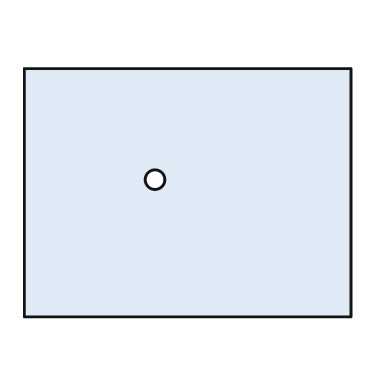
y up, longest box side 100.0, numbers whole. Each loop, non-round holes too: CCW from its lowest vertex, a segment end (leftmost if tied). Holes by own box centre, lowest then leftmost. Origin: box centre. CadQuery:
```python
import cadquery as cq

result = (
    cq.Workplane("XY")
    .moveTo(-50.0, -38.0)
    .lineTo(50.0, -38.0)
    .lineTo(50.0, 38.0)
    .lineTo(-50.0, 38.0)
    .close()
    .moveTo(-10.0, 4.0)
    .circle(3.0)
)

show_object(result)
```